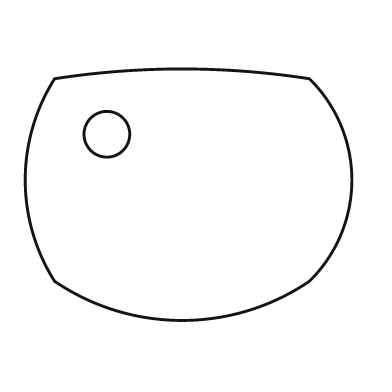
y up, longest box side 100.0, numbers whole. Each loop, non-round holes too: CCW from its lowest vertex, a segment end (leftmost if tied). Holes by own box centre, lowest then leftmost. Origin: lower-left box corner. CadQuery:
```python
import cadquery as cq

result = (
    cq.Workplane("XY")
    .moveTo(9.0, 12.0)
    .threePointArc((48.0, 0.0), (87.0, 12.0))
    .threePointArc((100.0, 43.0), (87.0, 74.0))
    .threePointArc((48.0, 77.0), (9.0, 74.0))
    .threePointArc((0.0, 43.0), (9.0, 12.0))
    .close()
    .moveTo(25.0, 57.0)
    .circle(7.0)
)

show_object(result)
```